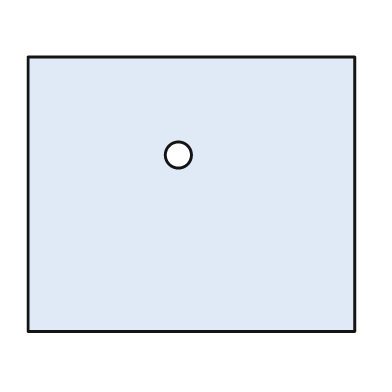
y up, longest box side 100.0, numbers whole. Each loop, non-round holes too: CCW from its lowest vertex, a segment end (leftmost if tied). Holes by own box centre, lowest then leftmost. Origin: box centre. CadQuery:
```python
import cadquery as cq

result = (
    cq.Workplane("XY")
    .moveTo(-50.0, -42.0)
    .lineTo(50.0, -42.0)
    .lineTo(50.0, 42.0)
    .lineTo(-50.0, 42.0)
    .close()
    .moveTo(-4.0, 12.0)
    .circle(4.0)
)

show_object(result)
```